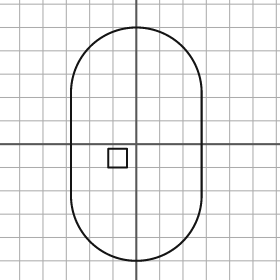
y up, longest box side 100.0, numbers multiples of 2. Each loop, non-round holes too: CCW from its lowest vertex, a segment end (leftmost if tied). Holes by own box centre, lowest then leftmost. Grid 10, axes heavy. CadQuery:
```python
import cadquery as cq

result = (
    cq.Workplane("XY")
    .moveTo(-28.0, -22.0)
    .threePointArc((0.0, -50.0), (28.0, -22.0))
    .lineTo(28.0, 22.0)
    .threePointArc((0.0, 50.0), (-28.0, 22.0))
    .close()
    .moveTo(-12.0, -10.0)
    .lineTo(-4.0, -10.0)
    .lineTo(-4.0, -2.0)
    .lineTo(-12.0, -2.0)
    .close()
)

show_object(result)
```